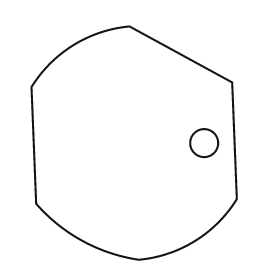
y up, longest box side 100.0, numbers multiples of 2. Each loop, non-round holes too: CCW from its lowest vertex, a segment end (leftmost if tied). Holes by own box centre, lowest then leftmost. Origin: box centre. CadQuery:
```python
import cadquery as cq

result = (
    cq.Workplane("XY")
    .moveTo(2.0, -50.0)
    .threePointArc((26.0, -42.0), (44.0, -24.0))
    .lineTo(42.0, 26.0)
    .lineTo(-2.0, 50.0)
    .threePointArc((-26.0, 42.0), (-44.0, 24.0))
    .lineTo(-42.0, -26.0)
    .threePointArc((-22.0, -42.0), (2.0, -50.0))
    .close()
    .moveTo(30.0, 0.0)
    .circle(6.0)
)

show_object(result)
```